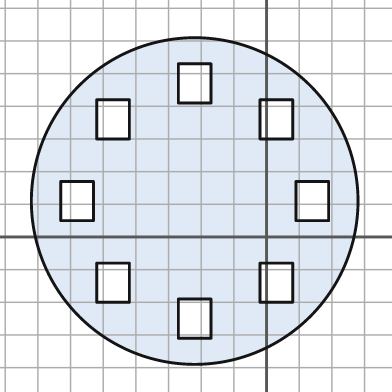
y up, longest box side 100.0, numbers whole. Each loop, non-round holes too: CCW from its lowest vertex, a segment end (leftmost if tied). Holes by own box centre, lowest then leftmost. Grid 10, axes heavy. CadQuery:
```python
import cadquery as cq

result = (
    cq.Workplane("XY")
    .moveTo(-22.0, 11.0)
    .circle(50.0)
    .moveTo(-27.0, -31.0)
    .lineTo(-17.0, -31.0)
    .lineTo(-17.0, -19.0)
    .lineTo(-27.0, -19.0)
    .close()
    .moveTo(-52.0, -20.0)
    .lineTo(-42.0, -20.0)
    .lineTo(-42.0, -8.0)
    .lineTo(-52.0, -8.0)
    .close()
    .moveTo(-2.0, -20.0)
    .lineTo(8.0, -20.0)
    .lineTo(8.0, -8.0)
    .lineTo(-2.0, -8.0)
    .close()
    .moveTo(-63.0, 5.0)
    .lineTo(-53.0, 5.0)
    .lineTo(-53.0, 17.0)
    .lineTo(-63.0, 17.0)
    .close()
    .moveTo(9.0, 5.0)
    .lineTo(19.0, 5.0)
    .lineTo(19.0, 17.0)
    .lineTo(9.0, 17.0)
    .close()
    .moveTo(-52.0, 30.0)
    .lineTo(-42.0, 30.0)
    .lineTo(-42.0, 42.0)
    .lineTo(-52.0, 42.0)
    .close()
    .moveTo(-2.0, 30.0)
    .lineTo(8.0, 30.0)
    .lineTo(8.0, 42.0)
    .lineTo(-2.0, 42.0)
    .close()
    .moveTo(-27.0, 41.0)
    .lineTo(-17.0, 41.0)
    .lineTo(-17.0, 53.0)
    .lineTo(-27.0, 53.0)
    .close()
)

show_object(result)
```